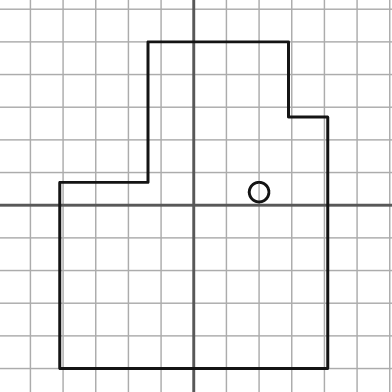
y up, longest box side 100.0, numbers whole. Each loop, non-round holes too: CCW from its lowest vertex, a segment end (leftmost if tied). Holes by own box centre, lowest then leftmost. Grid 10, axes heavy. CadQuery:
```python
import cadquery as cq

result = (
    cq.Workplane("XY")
    .moveTo(-41.0, -50.0)
    .lineTo(41.0, -50.0)
    .lineTo(41.0, 27.0)
    .lineTo(29.0, 27.0)
    .lineTo(29.0, 50.0)
    .lineTo(-14.0, 50.0)
    .lineTo(-14.0, 7.0)
    .lineTo(-41.0, 7.0)
    .close()
    .moveTo(20.0, 4.0)
    .circle(3.0)
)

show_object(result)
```